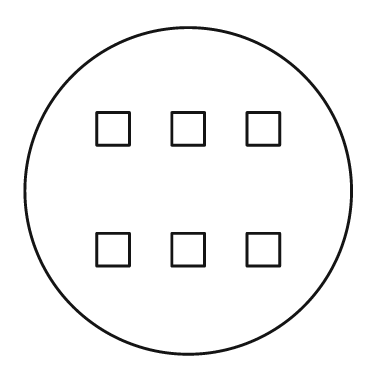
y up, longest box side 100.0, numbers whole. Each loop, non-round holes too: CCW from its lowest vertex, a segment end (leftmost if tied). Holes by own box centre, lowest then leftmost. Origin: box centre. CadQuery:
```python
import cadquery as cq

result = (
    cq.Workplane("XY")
    .moveTo(0.0, 0.0)
    .circle(50.0)
    .moveTo(-28.0, -23.0)
    .lineTo(-18.0, -23.0)
    .lineTo(-18.0, -13.0)
    .lineTo(-28.0, -13.0)
    .close()
    .moveTo(-5.0, -23.0)
    .lineTo(5.0, -23.0)
    .lineTo(5.0, -13.0)
    .lineTo(-5.0, -13.0)
    .close()
    .moveTo(18.0, -23.0)
    .lineTo(28.0, -23.0)
    .lineTo(28.0, -13.0)
    .lineTo(18.0, -13.0)
    .close()
    .moveTo(-28.0, 14.0)
    .lineTo(-18.0, 14.0)
    .lineTo(-18.0, 24.0)
    .lineTo(-28.0, 24.0)
    .close()
    .moveTo(-5.0, 14.0)
    .lineTo(5.0, 14.0)
    .lineTo(5.0, 24.0)
    .lineTo(-5.0, 24.0)
    .close()
    .moveTo(18.0, 14.0)
    .lineTo(28.0, 14.0)
    .lineTo(28.0, 24.0)
    .lineTo(18.0, 24.0)
    .close()
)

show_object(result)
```